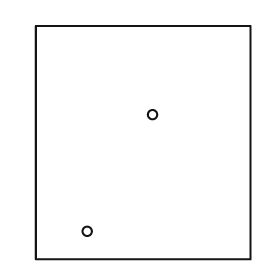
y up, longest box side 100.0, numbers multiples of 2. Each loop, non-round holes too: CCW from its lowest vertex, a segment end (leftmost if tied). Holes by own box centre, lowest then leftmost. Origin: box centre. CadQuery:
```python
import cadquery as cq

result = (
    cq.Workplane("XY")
    .moveTo(-46.0, -50.0)
    .lineTo(46.0, -50.0)
    .lineTo(46.0, 50.0)
    .lineTo(-46.0, 50.0)
    .close()
    .moveTo(-24.0, -38.0)
    .circle(2.0)
    .moveTo(4.0, 12.0)
    .circle(2.0)
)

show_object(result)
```